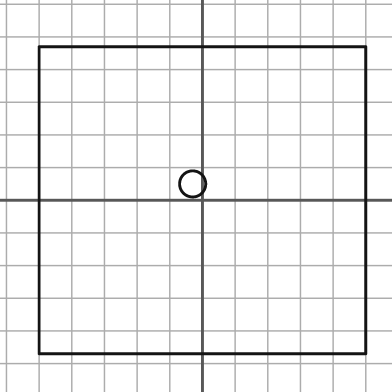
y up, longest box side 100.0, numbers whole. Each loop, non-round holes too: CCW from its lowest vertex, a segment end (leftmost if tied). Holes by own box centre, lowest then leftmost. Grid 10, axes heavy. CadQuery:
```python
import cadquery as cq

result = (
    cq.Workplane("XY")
    .moveTo(-50.0, -47.0)
    .lineTo(50.0, -47.0)
    .lineTo(50.0, 47.0)
    .lineTo(-50.0, 47.0)
    .close()
    .moveTo(-3.0, 5.0)
    .circle(4.0)
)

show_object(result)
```